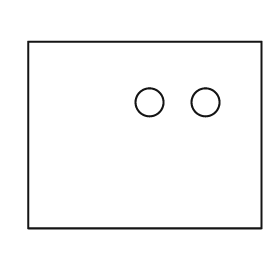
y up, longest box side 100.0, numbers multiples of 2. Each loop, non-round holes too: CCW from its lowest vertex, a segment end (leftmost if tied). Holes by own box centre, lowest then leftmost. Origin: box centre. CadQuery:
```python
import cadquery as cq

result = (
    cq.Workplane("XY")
    .moveTo(-50.0, -40.0)
    .lineTo(50.0, -40.0)
    .lineTo(50.0, 40.0)
    .lineTo(-50.0, 40.0)
    .close()
    .moveTo(2.0, 14.0)
    .circle(6.0)
    .moveTo(26.0, 14.0)
    .circle(6.0)
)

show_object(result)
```